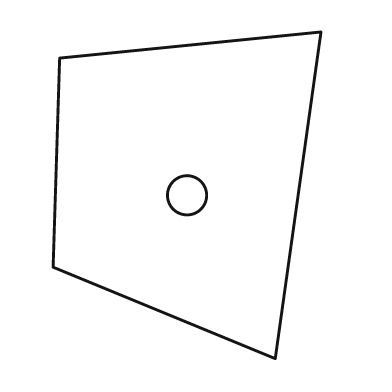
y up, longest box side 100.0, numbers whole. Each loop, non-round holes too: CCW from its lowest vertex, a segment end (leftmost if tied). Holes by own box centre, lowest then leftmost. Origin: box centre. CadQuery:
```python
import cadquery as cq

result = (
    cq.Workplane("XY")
    .moveTo(27.0, -50.0)
    .lineTo(41.0, 50.0)
    .lineTo(-39.0, 42.0)
    .lineTo(-41.0, -22.0)
    .close()
    .moveTo(0.0, 0.0)
    .circle(6.0)
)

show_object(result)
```